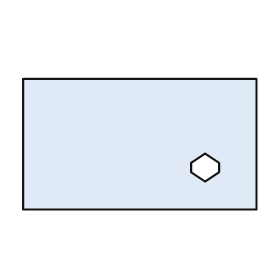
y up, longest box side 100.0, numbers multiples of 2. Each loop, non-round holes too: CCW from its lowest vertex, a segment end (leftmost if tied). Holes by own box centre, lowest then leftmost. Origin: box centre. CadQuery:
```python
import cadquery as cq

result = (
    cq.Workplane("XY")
    .moveTo(-50.0, -28.0)
    .lineTo(50.0, -28.0)
    .lineTo(50.0, 28.0)
    .lineTo(-50.0, 28.0)
    .close()
    .moveTo(28.0, -16.0)
    .lineTo(34.0, -12.0)
    .lineTo(34.0, -8.0)
    .lineTo(28.0, -4.0)
    .lineTo(22.0, -8.0)
    .lineTo(22.0, -12.0)
    .close()
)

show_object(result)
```